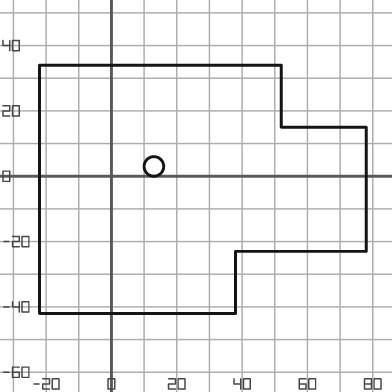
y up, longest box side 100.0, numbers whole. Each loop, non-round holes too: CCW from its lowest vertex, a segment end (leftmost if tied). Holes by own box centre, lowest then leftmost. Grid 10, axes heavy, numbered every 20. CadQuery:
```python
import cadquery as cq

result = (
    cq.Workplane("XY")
    .moveTo(-22.0, -42.0)
    .lineTo(38.0, -42.0)
    .lineTo(38.0, -23.0)
    .lineTo(78.0, -23.0)
    .lineTo(78.0, 15.0)
    .lineTo(52.0, 15.0)
    .lineTo(52.0, 34.0)
    .lineTo(-22.0, 34.0)
    .close()
    .moveTo(13.0, 3.0)
    .circle(3.0)
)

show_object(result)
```